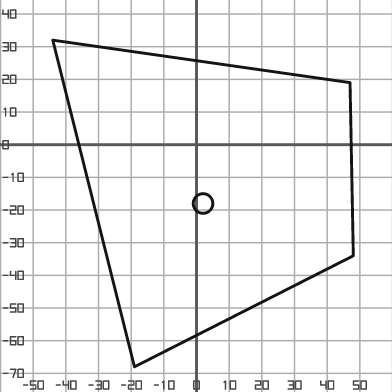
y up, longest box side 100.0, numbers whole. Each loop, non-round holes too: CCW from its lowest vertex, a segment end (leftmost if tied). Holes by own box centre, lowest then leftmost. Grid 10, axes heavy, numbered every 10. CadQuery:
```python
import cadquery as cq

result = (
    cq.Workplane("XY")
    .moveTo(-19.0, -68.0)
    .lineTo(48.0, -34.0)
    .lineTo(47.0, 19.0)
    .lineTo(-44.0, 32.0)
    .close()
    .moveTo(2.0, -18.0)
    .circle(3.0)
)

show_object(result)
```